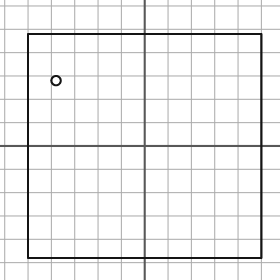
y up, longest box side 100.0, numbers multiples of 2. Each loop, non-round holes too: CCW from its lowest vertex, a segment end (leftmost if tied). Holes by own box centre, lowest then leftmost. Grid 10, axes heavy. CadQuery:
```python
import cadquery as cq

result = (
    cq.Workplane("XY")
    .moveTo(-50.0, -48.0)
    .lineTo(50.0, -48.0)
    .lineTo(50.0, 48.0)
    .lineTo(-50.0, 48.0)
    .close()
    .moveTo(-38.0, 28.0)
    .circle(2.0)
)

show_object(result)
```